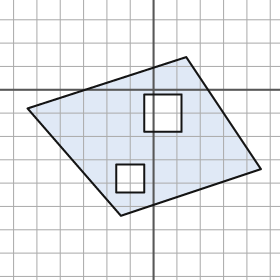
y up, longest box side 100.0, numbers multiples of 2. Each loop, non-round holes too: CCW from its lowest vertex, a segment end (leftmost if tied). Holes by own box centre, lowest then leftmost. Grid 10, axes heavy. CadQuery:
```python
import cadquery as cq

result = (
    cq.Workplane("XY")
    .moveTo(-14.0, -54.0)
    .lineTo(46.0, -34.0)
    .lineTo(14.0, 14.0)
    .lineTo(-54.0, -8.0)
    .close()
    .moveTo(-16.0, -44.0)
    .lineTo(-4.0, -44.0)
    .lineTo(-4.0, -32.0)
    .lineTo(-16.0, -32.0)
    .close()
    .moveTo(-4.0, -18.0)
    .lineTo(12.0, -18.0)
    .lineTo(12.0, -2.0)
    .lineTo(-4.0, -2.0)
    .close()
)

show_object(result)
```